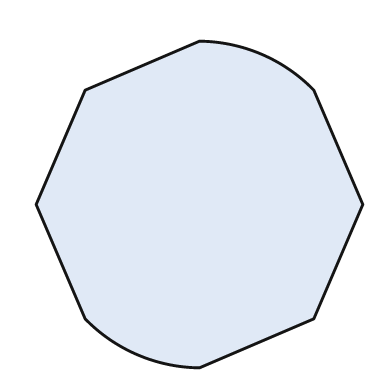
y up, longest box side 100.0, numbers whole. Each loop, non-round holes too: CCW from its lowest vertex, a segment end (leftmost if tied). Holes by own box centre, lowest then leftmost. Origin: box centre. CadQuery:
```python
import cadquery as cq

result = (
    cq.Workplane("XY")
    .moveTo(0.0, -50.0)
    .lineTo(35.0, -35.0)
    .lineTo(50.0, 0.0)
    .lineTo(35.0, 35.0)
    .threePointArc((19.0, 46.0), (0.0, 50.0))
    .lineTo(-35.0, 35.0)
    .lineTo(-50.0, 0.0)
    .lineTo(-35.0, -35.0)
    .threePointArc((-19.0, -46.0), (0.0, -50.0))
    .close()
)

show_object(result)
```